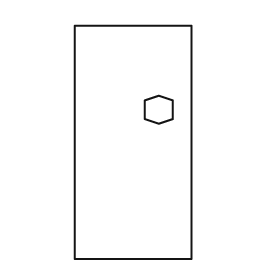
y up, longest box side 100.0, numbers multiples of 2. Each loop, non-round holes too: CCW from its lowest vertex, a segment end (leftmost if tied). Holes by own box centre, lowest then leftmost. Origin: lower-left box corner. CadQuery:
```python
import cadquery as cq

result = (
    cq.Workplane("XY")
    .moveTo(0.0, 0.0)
    .lineTo(50.0, 0.0)
    .lineTo(50.0, 100.0)
    .lineTo(0.0, 100.0)
    .close()
    .moveTo(36.0, 58.0)
    .lineTo(42.0, 60.0)
    .lineTo(42.0, 68.0)
    .lineTo(36.0, 70.0)
    .lineTo(30.0, 68.0)
    .lineTo(30.0, 60.0)
    .close()
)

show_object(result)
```